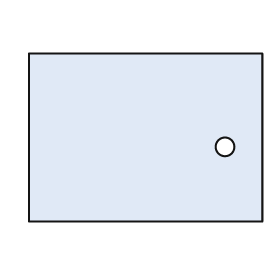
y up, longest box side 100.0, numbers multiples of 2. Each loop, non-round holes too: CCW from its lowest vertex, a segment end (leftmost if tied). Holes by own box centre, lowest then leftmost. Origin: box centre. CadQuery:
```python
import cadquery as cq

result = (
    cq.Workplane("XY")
    .moveTo(-50.0, -36.0)
    .lineTo(50.0, -36.0)
    .lineTo(50.0, 36.0)
    .lineTo(-50.0, 36.0)
    .close()
    .moveTo(34.0, -4.0)
    .circle(4.0)
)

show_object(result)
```